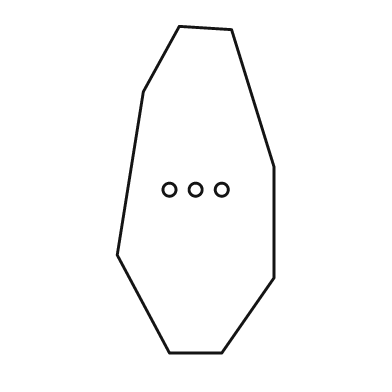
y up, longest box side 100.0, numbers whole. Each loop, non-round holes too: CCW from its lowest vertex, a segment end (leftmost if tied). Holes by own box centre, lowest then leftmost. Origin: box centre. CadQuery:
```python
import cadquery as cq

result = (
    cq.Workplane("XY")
    .moveTo(-8.0, -50.0)
    .lineTo(8.0, -50.0)
    .lineTo(24.0, -27.0)
    .lineTo(24.0, 7.0)
    .lineTo(11.0, 49.0)
    .lineTo(-5.0, 50.0)
    .lineTo(-16.0, 30.0)
    .lineTo(-24.0, -20.0)
    .close()
    .moveTo(-8.0, 0.0)
    .circle(2.0)
    .moveTo(0.0, 0.0)
    .circle(2.0)
    .moveTo(8.0, 0.0)
    .circle(2.0)
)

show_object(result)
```